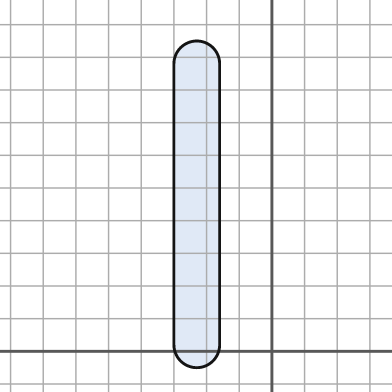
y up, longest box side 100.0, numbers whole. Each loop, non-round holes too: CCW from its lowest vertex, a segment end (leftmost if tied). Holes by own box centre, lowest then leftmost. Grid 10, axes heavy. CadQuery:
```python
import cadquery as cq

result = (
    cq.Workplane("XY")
    .moveTo(-30.0, 2.0)
    .threePointArc((-23.0, -5.0), (-16.0, 2.0))
    .lineTo(-16.0, 88.0)
    .threePointArc((-23.0, 95.0), (-30.0, 88.0))
    .close()
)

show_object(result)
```